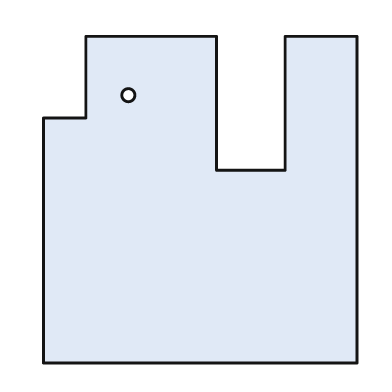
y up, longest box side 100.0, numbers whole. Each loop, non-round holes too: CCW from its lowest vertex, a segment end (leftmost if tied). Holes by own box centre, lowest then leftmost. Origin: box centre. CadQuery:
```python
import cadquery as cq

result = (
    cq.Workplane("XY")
    .moveTo(-48.0, -50.0)
    .lineTo(48.0, -50.0)
    .lineTo(48.0, 50.0)
    .lineTo(26.0, 50.0)
    .lineTo(26.0, 9.0)
    .lineTo(5.0, 9.0)
    .lineTo(5.0, 50.0)
    .lineTo(-35.0, 50.0)
    .lineTo(-35.0, 25.0)
    .lineTo(-48.0, 25.0)
    .close()
    .moveTo(-22.0, 32.0)
    .circle(2.0)
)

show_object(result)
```